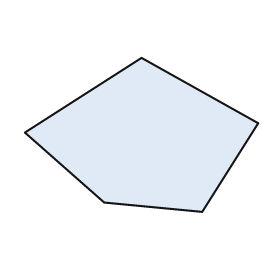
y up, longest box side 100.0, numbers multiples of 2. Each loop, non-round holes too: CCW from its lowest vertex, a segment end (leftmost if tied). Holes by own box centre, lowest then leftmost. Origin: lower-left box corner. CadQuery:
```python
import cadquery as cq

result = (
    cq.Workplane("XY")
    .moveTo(76.0, 0.0)
    .lineTo(100.0, 38.0)
    .lineTo(50.0, 66.0)
    .lineTo(0.0, 34.0)
    .lineTo(34.0, 4.0)
    .close()
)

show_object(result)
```